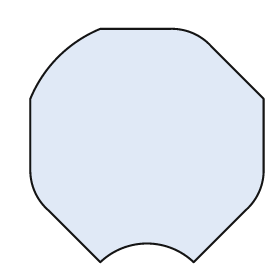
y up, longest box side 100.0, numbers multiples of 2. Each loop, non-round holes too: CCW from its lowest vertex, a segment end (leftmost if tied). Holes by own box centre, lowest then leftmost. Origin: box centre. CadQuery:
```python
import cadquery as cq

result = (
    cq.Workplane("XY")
    .moveTo(-20.0, -50.0)
    .threePointArc((0.0, -42.0), (20.0, -50.0))
    .lineTo(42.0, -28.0)
    .threePointArc((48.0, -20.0), (50.0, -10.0))
    .lineTo(50.0, 20.0)
    .lineTo(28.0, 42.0)
    .threePointArc((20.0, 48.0), (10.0, 50.0))
    .lineTo(-20.0, 50.0)
    .threePointArc((-38.0, 38.0), (-50.0, 20.0))
    .lineTo(-50.0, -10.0)
    .threePointArc((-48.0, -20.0), (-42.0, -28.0))
    .close()
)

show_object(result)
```